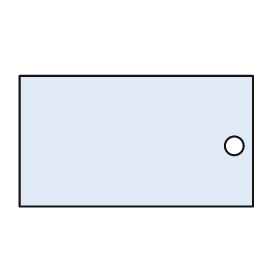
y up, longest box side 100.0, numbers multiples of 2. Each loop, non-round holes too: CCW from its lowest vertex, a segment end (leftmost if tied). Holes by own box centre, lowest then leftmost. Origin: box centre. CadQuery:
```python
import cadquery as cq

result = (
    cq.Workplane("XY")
    .moveTo(-50.0, -28.0)
    .lineTo(50.0, -28.0)
    .lineTo(50.0, 28.0)
    .lineTo(-50.0, 28.0)
    .close()
    .moveTo(42.0, -2.0)
    .circle(4.0)
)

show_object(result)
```